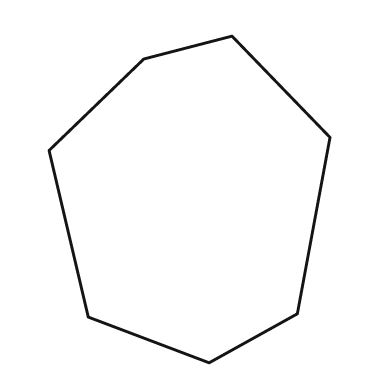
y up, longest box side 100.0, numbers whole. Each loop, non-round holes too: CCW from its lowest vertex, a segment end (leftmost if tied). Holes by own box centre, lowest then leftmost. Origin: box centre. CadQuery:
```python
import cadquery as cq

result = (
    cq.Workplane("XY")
    .moveTo(6.0, -50.0)
    .lineTo(33.0, -35.0)
    .lineTo(43.0, 19.0)
    .lineTo(13.0, 50.0)
    .lineTo(-14.0, 43.0)
    .lineTo(-43.0, 15.0)
    .lineTo(-31.0, -36.0)
    .close()
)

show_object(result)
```